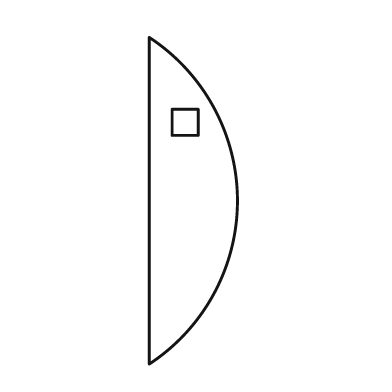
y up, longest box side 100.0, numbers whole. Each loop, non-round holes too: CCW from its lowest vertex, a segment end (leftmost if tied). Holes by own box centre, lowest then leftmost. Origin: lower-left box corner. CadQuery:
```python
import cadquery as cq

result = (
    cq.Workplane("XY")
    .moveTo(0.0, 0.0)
    .threePointArc((27.0, 50.0), (0.0, 100.0))
    .close()
    .moveTo(7.0, 70.0)
    .lineTo(15.0, 70.0)
    .lineTo(15.0, 78.0)
    .lineTo(7.0, 78.0)
    .close()
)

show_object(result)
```